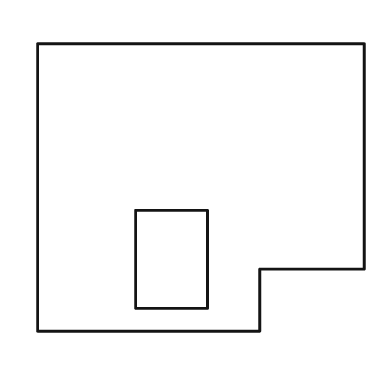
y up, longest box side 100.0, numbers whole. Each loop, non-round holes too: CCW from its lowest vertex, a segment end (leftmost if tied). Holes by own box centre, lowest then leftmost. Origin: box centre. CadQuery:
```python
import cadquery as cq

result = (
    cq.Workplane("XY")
    .moveTo(-50.0, -44.0)
    .lineTo(18.0, -44.0)
    .lineTo(18.0, -25.0)
    .lineTo(50.0, -25.0)
    .lineTo(50.0, 44.0)
    .lineTo(-50.0, 44.0)
    .close()
    .moveTo(-20.0, -37.0)
    .lineTo(2.0, -37.0)
    .lineTo(2.0, -7.0)
    .lineTo(-20.0, -7.0)
    .close()
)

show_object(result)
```